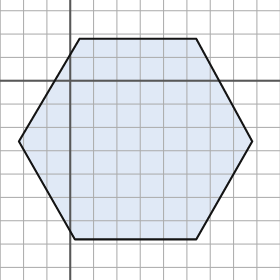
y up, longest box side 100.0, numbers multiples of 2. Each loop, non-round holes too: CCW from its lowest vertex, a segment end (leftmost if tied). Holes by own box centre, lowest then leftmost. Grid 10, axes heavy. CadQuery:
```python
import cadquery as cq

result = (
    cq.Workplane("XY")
    .moveTo(2.0, -68.0)
    .lineTo(54.0, -68.0)
    .lineTo(78.0, -26.0)
    .lineTo(54.0, 18.0)
    .lineTo(4.0, 18.0)
    .lineTo(-22.0, -26.0)
    .close()
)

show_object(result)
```